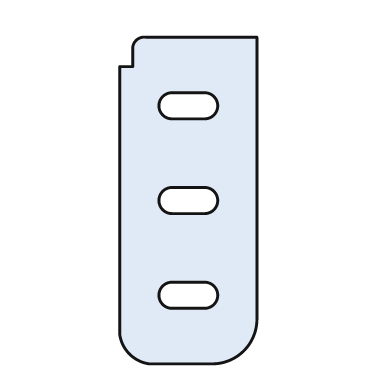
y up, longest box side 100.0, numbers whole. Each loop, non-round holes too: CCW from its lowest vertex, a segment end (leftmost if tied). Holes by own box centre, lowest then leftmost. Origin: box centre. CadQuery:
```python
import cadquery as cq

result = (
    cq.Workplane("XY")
    .moveTo(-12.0, -50.0)
    .lineTo(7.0, -50.0)
    .threePointArc((17.0, -46.0), (21.0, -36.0))
    .lineTo(21.0, 50.0)
    .lineTo(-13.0, 50.0)
    .threePointArc((-16.0, 49.0), (-17.0, 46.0))
    .lineTo(-17.0, 41.0)
    .lineTo(-21.0, 41.0)
    .lineTo(-21.0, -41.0)
    .threePointArc((-18.0, -47.0), (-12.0, -50.0))
    .close()
    .moveTo(-5.0, -33.0)
    .lineTo(5.0, -33.0)
    .threePointArc((9.0, -29.0), (5.0, -25.0))
    .lineTo(-5.0, -25.0)
    .threePointArc((-9.0, -29.0), (-5.0, -33.0))
    .close()
    .moveTo(-5.0, -4.0)
    .lineTo(5.0, -4.0)
    .threePointArc((9.0, 0.0), (5.0, 4.0))
    .lineTo(-5.0, 4.0)
    .threePointArc((-9.0, 0.0), (-5.0, -4.0))
    .close()
    .moveTo(-5.0, 25.0)
    .lineTo(5.0, 25.0)
    .threePointArc((9.0, 29.0), (5.0, 33.0))
    .lineTo(-5.0, 33.0)
    .threePointArc((-9.0, 29.0), (-5.0, 25.0))
    .close()
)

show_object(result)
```